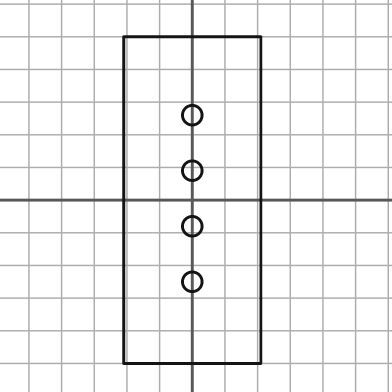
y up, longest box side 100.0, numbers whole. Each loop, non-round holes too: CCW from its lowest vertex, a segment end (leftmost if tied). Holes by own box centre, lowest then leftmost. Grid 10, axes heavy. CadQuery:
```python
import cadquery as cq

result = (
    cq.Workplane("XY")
    .moveTo(-21.0, -50.0)
    .lineTo(21.0, -50.0)
    .lineTo(21.0, 50.0)
    .lineTo(-21.0, 50.0)
    .close()
    .moveTo(0.0, -25.0)
    .circle(3.0)
    .moveTo(0.0, -8.0)
    .circle(3.0)
    .moveTo(0.0, 9.0)
    .circle(3.0)
    .moveTo(0.0, 26.0)
    .circle(3.0)
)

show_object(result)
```